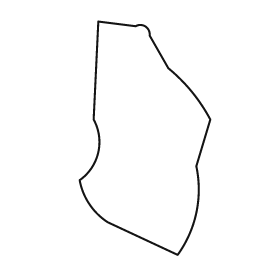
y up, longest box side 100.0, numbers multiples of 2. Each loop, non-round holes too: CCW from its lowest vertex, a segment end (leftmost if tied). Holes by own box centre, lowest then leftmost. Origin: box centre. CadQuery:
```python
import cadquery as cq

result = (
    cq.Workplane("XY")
    .moveTo(14.0, -50.0)
    .threePointArc((22.0, -32.0), (22.0, -12.0))
    .lineTo(28.0, 8.0)
    .threePointArc((20.0, 20.0), (10.0, 30.0))
    .lineTo(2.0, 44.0)
    .threePointArc((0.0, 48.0), (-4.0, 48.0))
    .lineTo(-20.0, 50.0)
    .lineTo(-22.0, 8.0)
    .threePointArc((-20.0, -6.0), (-28.0, -18.0))
    .threePointArc((-24.0, -28.0), (-16.0, -36.0))
    .close()
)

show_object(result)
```